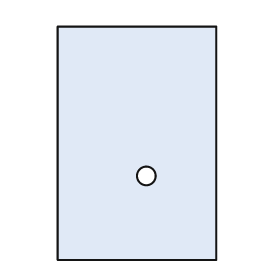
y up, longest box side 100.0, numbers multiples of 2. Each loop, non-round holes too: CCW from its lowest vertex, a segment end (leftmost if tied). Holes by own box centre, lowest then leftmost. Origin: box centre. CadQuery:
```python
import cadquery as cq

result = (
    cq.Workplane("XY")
    .moveTo(-34.0, -50.0)
    .lineTo(34.0, -50.0)
    .lineTo(34.0, 50.0)
    .lineTo(-34.0, 50.0)
    .close()
    .moveTo(4.0, -14.0)
    .circle(4.0)
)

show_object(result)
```